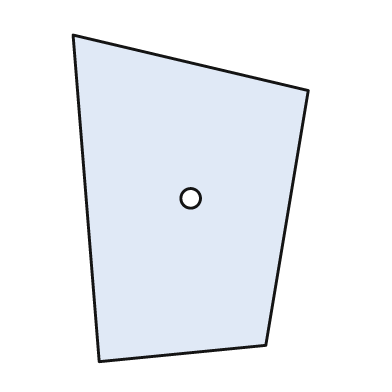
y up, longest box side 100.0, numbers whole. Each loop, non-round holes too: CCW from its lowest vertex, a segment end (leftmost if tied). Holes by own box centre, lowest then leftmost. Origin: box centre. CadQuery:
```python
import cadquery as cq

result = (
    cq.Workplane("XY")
    .moveTo(-28.0, -50.0)
    .lineTo(23.0, -45.0)
    .lineTo(36.0, 33.0)
    .lineTo(-36.0, 50.0)
    .close()
    .moveTo(0.0, 0.0)
    .circle(3.0)
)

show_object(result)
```